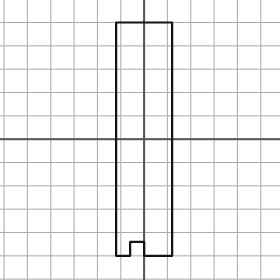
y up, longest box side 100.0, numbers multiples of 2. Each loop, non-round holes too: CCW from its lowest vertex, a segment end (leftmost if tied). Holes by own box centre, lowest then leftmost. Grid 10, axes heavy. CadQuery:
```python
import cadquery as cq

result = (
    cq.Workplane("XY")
    .moveTo(-12.0, -50.0)
    .lineTo(-6.0, -50.0)
    .lineTo(-6.0, -44.0)
    .lineTo(0.0, -44.0)
    .lineTo(0.0, -50.0)
    .lineTo(12.0, -50.0)
    .lineTo(12.0, 50.0)
    .lineTo(-12.0, 50.0)
    .close()
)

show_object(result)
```